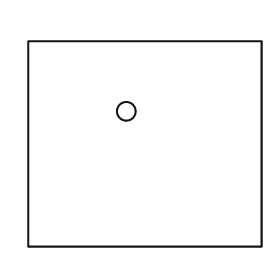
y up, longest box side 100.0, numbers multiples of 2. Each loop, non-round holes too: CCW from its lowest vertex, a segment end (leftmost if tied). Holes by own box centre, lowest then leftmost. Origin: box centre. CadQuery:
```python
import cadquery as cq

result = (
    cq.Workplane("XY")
    .moveTo(-50.0, -44.0)
    .lineTo(50.0, -44.0)
    .lineTo(50.0, 44.0)
    .lineTo(-50.0, 44.0)
    .close()
    .moveTo(-8.0, 14.0)
    .circle(4.0)
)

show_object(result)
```